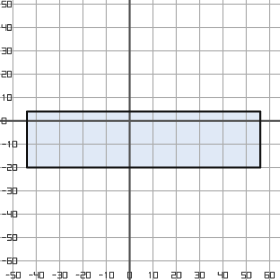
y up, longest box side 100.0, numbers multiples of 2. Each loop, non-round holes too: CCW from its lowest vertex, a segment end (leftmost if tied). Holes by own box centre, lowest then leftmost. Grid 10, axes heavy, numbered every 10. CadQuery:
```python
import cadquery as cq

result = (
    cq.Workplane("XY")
    .moveTo(-44.0, -20.0)
    .lineTo(56.0, -20.0)
    .lineTo(56.0, 4.0)
    .lineTo(-44.0, 4.0)
    .close()
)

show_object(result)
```